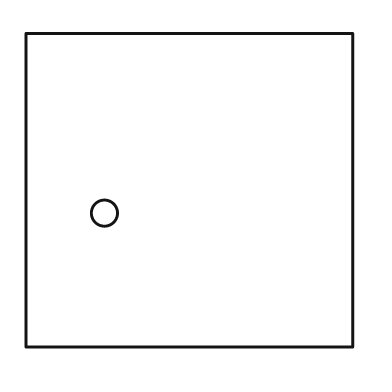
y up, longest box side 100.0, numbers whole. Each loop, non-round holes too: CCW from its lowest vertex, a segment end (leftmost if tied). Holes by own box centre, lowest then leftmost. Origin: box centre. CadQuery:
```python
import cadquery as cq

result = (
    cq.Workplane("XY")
    .moveTo(-50.0, -48.0)
    .lineTo(50.0, -48.0)
    .lineTo(50.0, 48.0)
    .lineTo(-50.0, 48.0)
    .close()
    .moveTo(-26.0, -7.0)
    .circle(4.0)
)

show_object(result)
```